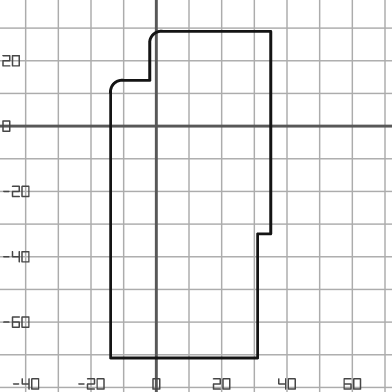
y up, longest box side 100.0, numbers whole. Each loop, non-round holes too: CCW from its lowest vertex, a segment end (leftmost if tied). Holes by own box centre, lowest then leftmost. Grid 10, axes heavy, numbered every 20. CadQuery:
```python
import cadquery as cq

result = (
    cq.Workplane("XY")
    .moveTo(-14.0, -71.0)
    .lineTo(31.0, -71.0)
    .lineTo(31.0, -33.0)
    .lineTo(35.0, -33.0)
    .lineTo(35.0, 29.0)
    .lineTo(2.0, 29.0)
    .threePointArc((-1.0, 28.0), (-2.0, 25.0))
    .lineTo(-2.0, 14.0)
    .lineTo(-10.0, 14.0)
    .threePointArc((-13.0, 13.0), (-14.0, 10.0))
    .close()
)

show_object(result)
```